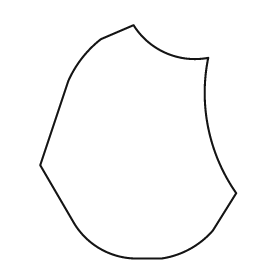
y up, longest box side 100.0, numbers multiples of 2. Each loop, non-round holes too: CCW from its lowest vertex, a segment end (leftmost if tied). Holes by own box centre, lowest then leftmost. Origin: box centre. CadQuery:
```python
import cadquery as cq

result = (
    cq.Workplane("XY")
    .moveTo(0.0, -50.0)
    .lineTo(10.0, -50.0)
    .threePointArc((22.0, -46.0), (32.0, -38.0))
    .lineTo(42.0, -22.0)
    .threePointArc((30.0, 6.0), (30.0, 36.0))
    .threePointArc((12.0, 38.0), (-2.0, 50.0))
    .lineTo(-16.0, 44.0)
    .threePointArc((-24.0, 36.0), (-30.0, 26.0))
    .lineTo(-42.0, -10.0)
    .lineTo(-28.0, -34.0)
    .threePointArc((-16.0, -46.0), (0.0, -50.0))
    .close()
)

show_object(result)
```